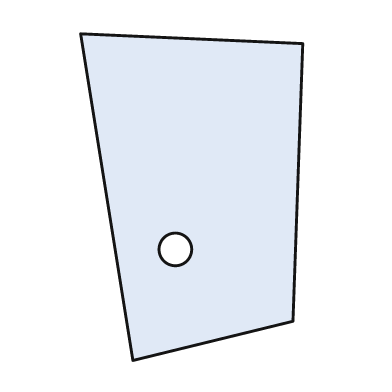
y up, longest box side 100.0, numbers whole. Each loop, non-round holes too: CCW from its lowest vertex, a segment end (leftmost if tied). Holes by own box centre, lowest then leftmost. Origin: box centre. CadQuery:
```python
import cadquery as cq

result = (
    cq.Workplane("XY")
    .moveTo(-18.0, -50.0)
    .lineTo(31.0, -38.0)
    .lineTo(34.0, 47.0)
    .lineTo(-34.0, 50.0)
    .close()
    .moveTo(-5.0, -16.0)
    .circle(5.0)
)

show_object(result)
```